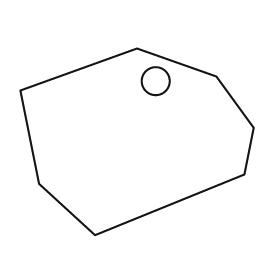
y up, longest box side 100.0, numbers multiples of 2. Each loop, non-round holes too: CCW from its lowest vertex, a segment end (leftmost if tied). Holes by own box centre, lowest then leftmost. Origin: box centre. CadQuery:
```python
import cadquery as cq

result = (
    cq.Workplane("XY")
    .moveTo(-18.0, -40.0)
    .lineTo(46.0, -14.0)
    .lineTo(50.0, 6.0)
    .lineTo(34.0, 28.0)
    .lineTo(0.0, 40.0)
    .lineTo(-50.0, 22.0)
    .lineTo(-42.0, -18.0)
    .close()
    .moveTo(8.0, 26.0)
    .circle(6.0)
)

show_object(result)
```